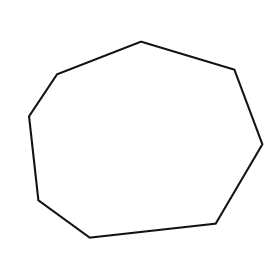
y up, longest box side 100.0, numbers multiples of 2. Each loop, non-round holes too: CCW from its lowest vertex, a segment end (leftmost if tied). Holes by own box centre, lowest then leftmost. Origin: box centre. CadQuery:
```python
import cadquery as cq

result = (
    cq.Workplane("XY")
    .moveTo(-24.0, -42.0)
    .lineTo(30.0, -36.0)
    .lineTo(50.0, -2.0)
    .lineTo(38.0, 30.0)
    .lineTo(-2.0, 42.0)
    .lineTo(-38.0, 28.0)
    .lineTo(-50.0, 10.0)
    .lineTo(-46.0, -26.0)
    .close()
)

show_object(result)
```